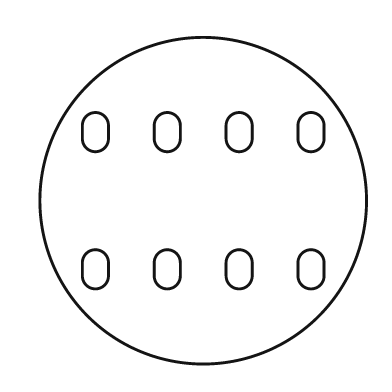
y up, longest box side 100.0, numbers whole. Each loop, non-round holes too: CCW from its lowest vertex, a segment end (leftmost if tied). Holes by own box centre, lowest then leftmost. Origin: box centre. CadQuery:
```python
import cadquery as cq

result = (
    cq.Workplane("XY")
    .moveTo(0.0, 0.0)
    .circle(50.0)
    .moveTo(-37.0, -23.0)
    .threePointArc((-33.0, -27.0), (-29.0, -23.0))
    .lineTo(-29.0, -19.0)
    .threePointArc((-33.0, -15.0), (-37.0, -19.0))
    .close()
    .moveTo(-15.0, -23.0)
    .threePointArc((-11.0, -27.0), (-7.0, -23.0))
    .lineTo(-7.0, -19.0)
    .threePointArc((-11.0, -15.0), (-15.0, -19.0))
    .close()
    .moveTo(7.0, -23.0)
    .threePointArc((11.0, -27.0), (15.0, -23.0))
    .lineTo(15.0, -19.0)
    .threePointArc((11.0, -15.0), (7.0, -19.0))
    .close()
    .moveTo(29.0, -23.0)
    .threePointArc((33.0, -27.0), (37.0, -23.0))
    .lineTo(37.0, -19.0)
    .threePointArc((33.0, -15.0), (29.0, -19.0))
    .close()
    .moveTo(-37.0, 19.0)
    .threePointArc((-33.0, 15.0), (-29.0, 19.0))
    .lineTo(-29.0, 23.0)
    .threePointArc((-33.0, 27.0), (-37.0, 23.0))
    .close()
    .moveTo(-15.0, 19.0)
    .threePointArc((-11.0, 15.0), (-7.0, 19.0))
    .lineTo(-7.0, 23.0)
    .threePointArc((-11.0, 27.0), (-15.0, 23.0))
    .close()
    .moveTo(7.0, 19.0)
    .threePointArc((11.0, 15.0), (15.0, 19.0))
    .lineTo(15.0, 23.0)
    .threePointArc((11.0, 27.0), (7.0, 23.0))
    .close()
    .moveTo(29.0, 19.0)
    .threePointArc((33.0, 15.0), (37.0, 19.0))
    .lineTo(37.0, 23.0)
    .threePointArc((33.0, 27.0), (29.0, 23.0))
    .close()
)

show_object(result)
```